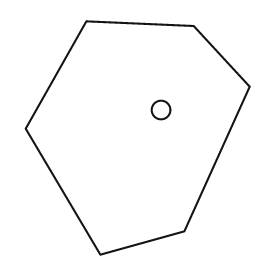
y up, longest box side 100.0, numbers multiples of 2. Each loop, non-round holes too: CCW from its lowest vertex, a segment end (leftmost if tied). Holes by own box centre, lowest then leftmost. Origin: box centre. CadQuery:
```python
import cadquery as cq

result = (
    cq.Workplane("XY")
    .moveTo(-16.0, -50.0)
    .lineTo(20.0, -40.0)
    .lineTo(48.0, 22.0)
    .lineTo(24.0, 48.0)
    .lineTo(-22.0, 50.0)
    .lineTo(-48.0, 4.0)
    .close()
    .moveTo(10.0, 12.0)
    .circle(4.0)
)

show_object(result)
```